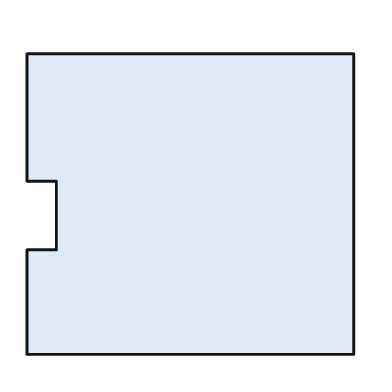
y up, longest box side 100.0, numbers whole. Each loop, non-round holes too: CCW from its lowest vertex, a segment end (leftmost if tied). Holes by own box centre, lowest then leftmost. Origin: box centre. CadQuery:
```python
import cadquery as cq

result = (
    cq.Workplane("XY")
    .moveTo(-50.0, -46.0)
    .lineTo(50.0, -46.0)
    .lineTo(50.0, 46.0)
    .lineTo(-50.0, 46.0)
    .lineTo(-50.0, 7.0)
    .lineTo(-41.0, 7.0)
    .lineTo(-41.0, -14.0)
    .lineTo(-50.0, -14.0)
    .close()
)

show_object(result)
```